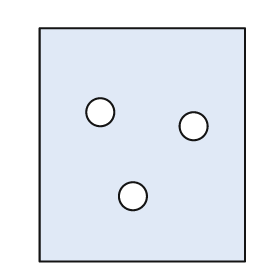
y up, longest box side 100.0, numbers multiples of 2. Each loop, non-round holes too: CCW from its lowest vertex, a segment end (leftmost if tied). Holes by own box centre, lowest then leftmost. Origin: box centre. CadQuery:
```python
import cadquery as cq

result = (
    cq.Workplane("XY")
    .moveTo(-44.0, -50.0)
    .lineTo(44.0, -50.0)
    .lineTo(44.0, 50.0)
    .lineTo(-44.0, 50.0)
    .close()
    .moveTo(-4.0, -22.0)
    .circle(6.0)
    .moveTo(22.0, 8.0)
    .circle(6.0)
    .moveTo(-18.0, 14.0)
    .circle(6.0)
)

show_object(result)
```